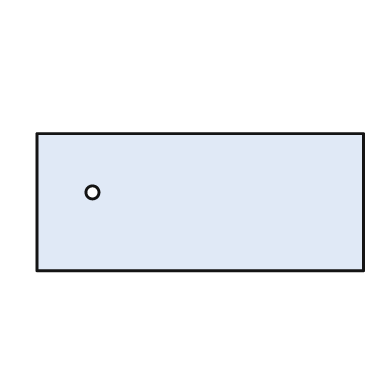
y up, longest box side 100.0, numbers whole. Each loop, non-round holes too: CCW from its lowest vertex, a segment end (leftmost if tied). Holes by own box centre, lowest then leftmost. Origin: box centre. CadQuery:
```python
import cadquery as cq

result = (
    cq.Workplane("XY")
    .moveTo(-50.0, -21.0)
    .lineTo(50.0, -21.0)
    .lineTo(50.0, 21.0)
    .lineTo(-50.0, 21.0)
    .close()
    .moveTo(-33.0, 3.0)
    .circle(2.0)
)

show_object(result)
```